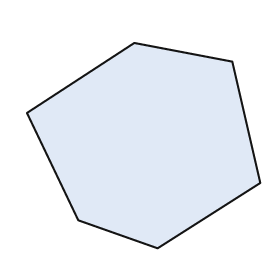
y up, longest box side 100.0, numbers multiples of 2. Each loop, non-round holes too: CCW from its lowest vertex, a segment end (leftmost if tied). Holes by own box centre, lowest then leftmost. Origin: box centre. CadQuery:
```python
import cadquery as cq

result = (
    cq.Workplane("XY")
    .moveTo(6.0, -44.0)
    .lineTo(50.0, -16.0)
    .lineTo(38.0, 36.0)
    .lineTo(-4.0, 44.0)
    .lineTo(-50.0, 14.0)
    .lineTo(-28.0, -32.0)
    .close()
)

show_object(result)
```